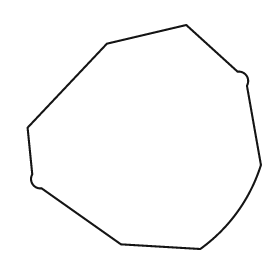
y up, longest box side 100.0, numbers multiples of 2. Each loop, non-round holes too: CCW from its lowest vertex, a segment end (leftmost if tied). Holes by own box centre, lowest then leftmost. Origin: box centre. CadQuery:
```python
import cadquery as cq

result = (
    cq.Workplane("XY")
    .moveTo(24.0, -48.0)
    .threePointArc((40.0, -32.0), (50.0, -12.0))
    .lineTo(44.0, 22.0)
    .threePointArc((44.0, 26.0), (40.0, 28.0))
    .lineTo(18.0, 48.0)
    .lineTo(-16.0, 40.0)
    .lineTo(-50.0, 4.0)
    .lineTo(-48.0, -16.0)
    .threePointArc((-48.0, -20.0), (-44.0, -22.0))
    .lineTo(-10.0, -46.0)
    .close()
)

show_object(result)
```